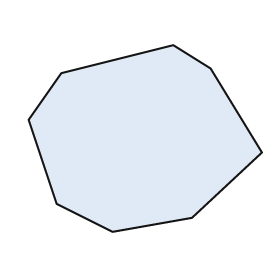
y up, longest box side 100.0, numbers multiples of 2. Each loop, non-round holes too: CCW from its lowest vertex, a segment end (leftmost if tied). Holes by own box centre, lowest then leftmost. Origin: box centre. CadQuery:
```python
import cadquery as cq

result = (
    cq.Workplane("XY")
    .moveTo(-14.0, -40.0)
    .lineTo(20.0, -34.0)
    .lineTo(50.0, -6.0)
    .lineTo(28.0, 30.0)
    .lineTo(12.0, 40.0)
    .lineTo(-36.0, 28.0)
    .lineTo(-50.0, 8.0)
    .lineTo(-38.0, -28.0)
    .close()
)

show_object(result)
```